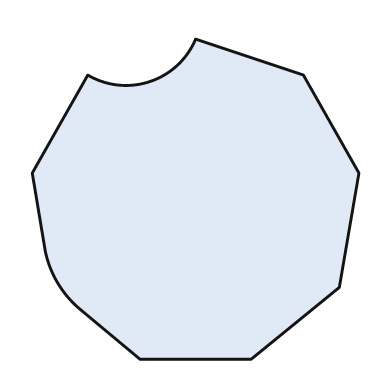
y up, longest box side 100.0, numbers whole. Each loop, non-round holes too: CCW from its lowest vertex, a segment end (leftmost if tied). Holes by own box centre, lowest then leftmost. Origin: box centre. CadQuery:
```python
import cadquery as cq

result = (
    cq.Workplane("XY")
    .moveTo(-17.0, -49.0)
    .lineTo(17.0, -49.0)
    .lineTo(44.0, -27.0)
    .lineTo(50.0, 8.0)
    .lineTo(33.0, 38.0)
    .lineTo(0.0, 49.0)
    .threePointArc((-14.0, 36.0), (-33.0, 38.0))
    .lineTo(-50.0, 8.0)
    .lineTo(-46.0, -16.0)
    .threePointArc((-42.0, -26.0), (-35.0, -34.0))
    .close()
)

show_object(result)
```